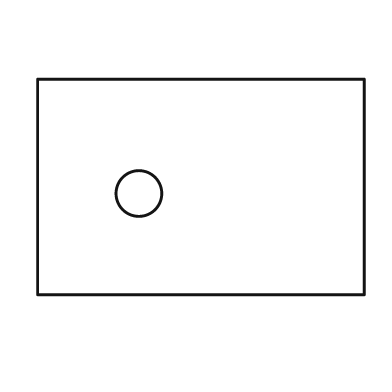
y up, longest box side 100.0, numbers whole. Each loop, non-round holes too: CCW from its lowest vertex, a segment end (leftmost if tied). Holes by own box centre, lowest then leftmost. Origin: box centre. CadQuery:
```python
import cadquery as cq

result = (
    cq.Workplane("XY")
    .moveTo(-50.0, -33.0)
    .lineTo(50.0, -33.0)
    .lineTo(50.0, 33.0)
    .lineTo(-50.0, 33.0)
    .close()
    .moveTo(-19.0, -2.0)
    .circle(7.0)
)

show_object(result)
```